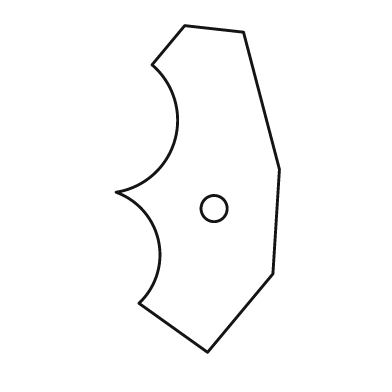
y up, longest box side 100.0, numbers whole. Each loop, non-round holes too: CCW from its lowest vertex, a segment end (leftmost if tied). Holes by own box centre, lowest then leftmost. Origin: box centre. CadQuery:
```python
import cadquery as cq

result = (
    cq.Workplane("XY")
    .moveTo(3.0, -50.0)
    .lineTo(23.0, -26.0)
    .lineTo(25.0, 6.0)
    .lineTo(14.0, 48.0)
    .lineTo(-4.0, 50.0)
    .lineTo(-14.0, 38.0)
    .threePointArc((-7.0, 15.0), (-25.0, -1.0))
    .threePointArc((-12.0, -16.0), (-18.0, -35.0))
    .close()
    .moveTo(5.0, -6.0)
    .circle(4.0)
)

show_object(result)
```